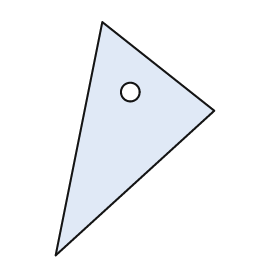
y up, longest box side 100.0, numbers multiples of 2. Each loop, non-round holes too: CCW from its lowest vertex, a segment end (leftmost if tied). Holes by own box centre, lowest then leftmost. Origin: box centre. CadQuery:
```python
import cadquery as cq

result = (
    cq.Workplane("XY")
    .moveTo(-34.0, -50.0)
    .lineTo(34.0, 12.0)
    .lineTo(-14.0, 50.0)
    .close()
    .moveTo(-2.0, 20.0)
    .circle(4.0)
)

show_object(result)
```